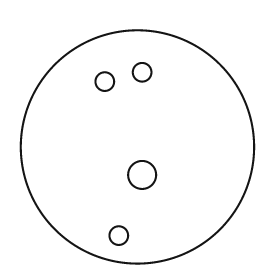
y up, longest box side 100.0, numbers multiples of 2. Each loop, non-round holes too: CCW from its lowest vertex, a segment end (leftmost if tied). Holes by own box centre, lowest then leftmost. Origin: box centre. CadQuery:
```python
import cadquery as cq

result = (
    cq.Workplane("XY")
    .moveTo(0.0, 0.0)
    .circle(50.0)
    .moveTo(-8.0, -38.0)
    .circle(4.0)
    .moveTo(2.0, -12.0)
    .circle(6.0)
    .moveTo(-14.0, 28.0)
    .circle(4.0)
    .moveTo(2.0, 32.0)
    .circle(4.0)
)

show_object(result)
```